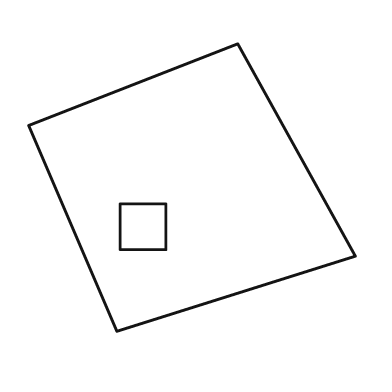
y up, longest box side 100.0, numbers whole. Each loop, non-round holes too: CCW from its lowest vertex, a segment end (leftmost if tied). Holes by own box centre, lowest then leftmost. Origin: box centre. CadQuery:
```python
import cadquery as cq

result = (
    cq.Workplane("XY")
    .moveTo(-23.0, -44.0)
    .lineTo(50.0, -21.0)
    .lineTo(14.0, 44.0)
    .lineTo(-50.0, 19.0)
    .close()
    .moveTo(-22.0, -19.0)
    .lineTo(-8.0, -19.0)
    .lineTo(-8.0, -5.0)
    .lineTo(-22.0, -5.0)
    .close()
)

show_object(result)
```